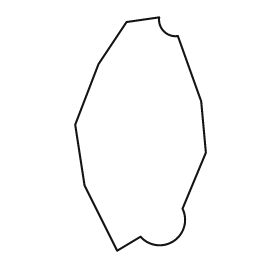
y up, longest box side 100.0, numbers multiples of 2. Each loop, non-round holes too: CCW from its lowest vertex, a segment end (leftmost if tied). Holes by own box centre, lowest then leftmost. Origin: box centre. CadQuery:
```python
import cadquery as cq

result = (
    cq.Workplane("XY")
    .moveTo(-10.0, -50.0)
    .lineTo(0.0, -44.0)
    .threePointArc((14.0, -46.0), (18.0, -32.0))
    .lineTo(28.0, -8.0)
    .lineTo(26.0, 14.0)
    .lineTo(16.0, 42.0)
    .threePointArc((10.0, 44.0), (8.0, 50.0))
    .lineTo(-6.0, 48.0)
    .lineTo(-18.0, 30.0)
    .lineTo(-28.0, 4.0)
    .lineTo(-24.0, -22.0)
    .close()
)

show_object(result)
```